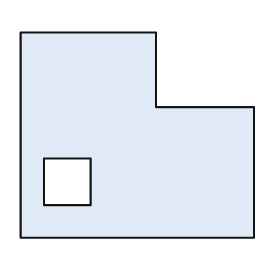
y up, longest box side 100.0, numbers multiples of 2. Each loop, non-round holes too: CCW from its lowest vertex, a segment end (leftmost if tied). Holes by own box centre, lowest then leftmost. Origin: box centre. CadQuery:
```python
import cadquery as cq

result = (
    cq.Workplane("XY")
    .moveTo(-50.0, -44.0)
    .lineTo(50.0, -44.0)
    .lineTo(50.0, 12.0)
    .lineTo(8.0, 12.0)
    .lineTo(8.0, 44.0)
    .lineTo(-50.0, 44.0)
    .close()
    .moveTo(-40.0, -30.0)
    .lineTo(-20.0, -30.0)
    .lineTo(-20.0, -10.0)
    .lineTo(-40.0, -10.0)
    .close()
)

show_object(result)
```